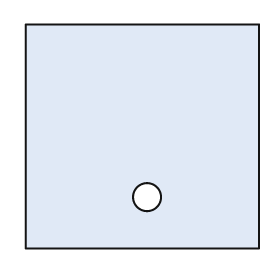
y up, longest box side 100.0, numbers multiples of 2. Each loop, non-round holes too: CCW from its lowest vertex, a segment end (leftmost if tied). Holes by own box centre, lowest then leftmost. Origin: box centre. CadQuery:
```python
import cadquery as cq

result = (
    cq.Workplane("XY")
    .moveTo(-50.0, -48.0)
    .lineTo(50.0, -48.0)
    .lineTo(50.0, 48.0)
    .lineTo(-50.0, 48.0)
    .close()
    .moveTo(2.0, -26.0)
    .circle(6.0)
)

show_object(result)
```